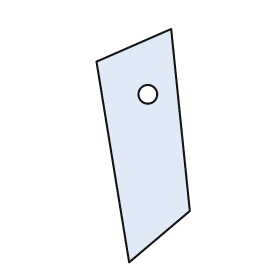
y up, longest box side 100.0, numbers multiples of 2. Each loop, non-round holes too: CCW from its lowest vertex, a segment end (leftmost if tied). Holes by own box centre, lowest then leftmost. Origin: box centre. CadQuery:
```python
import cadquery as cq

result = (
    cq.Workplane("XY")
    .moveTo(-6.0, -50.0)
    .lineTo(20.0, -28.0)
    .lineTo(12.0, 50.0)
    .lineTo(-20.0, 36.0)
    .close()
    .moveTo(2.0, 22.0)
    .circle(4.0)
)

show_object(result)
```